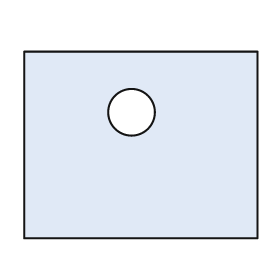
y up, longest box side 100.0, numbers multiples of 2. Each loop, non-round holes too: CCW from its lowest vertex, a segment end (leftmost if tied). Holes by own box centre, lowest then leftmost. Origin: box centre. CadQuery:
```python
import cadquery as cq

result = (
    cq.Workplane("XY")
    .moveTo(-50.0, -40.0)
    .lineTo(50.0, -40.0)
    .lineTo(50.0, 40.0)
    .lineTo(-50.0, 40.0)
    .close()
    .moveTo(-4.0, 14.0)
    .circle(10.0)
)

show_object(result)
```